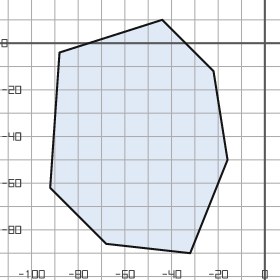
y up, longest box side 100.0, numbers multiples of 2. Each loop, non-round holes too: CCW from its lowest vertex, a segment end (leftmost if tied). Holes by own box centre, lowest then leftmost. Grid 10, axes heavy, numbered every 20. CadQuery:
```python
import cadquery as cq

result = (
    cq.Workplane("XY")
    .moveTo(-32.0, -90.0)
    .lineTo(-16.0, -50.0)
    .lineTo(-22.0, -12.0)
    .lineTo(-44.0, 10.0)
    .lineTo(-88.0, -4.0)
    .lineTo(-92.0, -62.0)
    .lineTo(-68.0, -86.0)
    .close()
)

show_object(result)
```